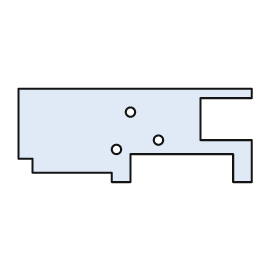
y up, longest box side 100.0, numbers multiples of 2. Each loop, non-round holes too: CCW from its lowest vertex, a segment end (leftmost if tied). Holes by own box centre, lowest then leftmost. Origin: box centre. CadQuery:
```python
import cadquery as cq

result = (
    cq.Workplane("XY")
    .moveTo(-10.0, -20.0)
    .lineTo(-2.0, -20.0)
    .lineTo(-2.0, -8.0)
    .lineTo(42.0, -8.0)
    .lineTo(42.0, -20.0)
    .lineTo(50.0, -20.0)
    .lineTo(50.0, -2.0)
    .lineTo(28.0, -2.0)
    .lineTo(28.0, 16.0)
    .lineTo(50.0, 16.0)
    .lineTo(50.0, 20.0)
    .lineTo(-50.0, 20.0)
    .lineTo(-50.0, -10.0)
    .lineTo(-44.0, -10.0)
    .lineTo(-44.0, -16.0)
    .lineTo(-10.0, -16.0)
    .close()
    .moveTo(-8.0, -6.0)
    .circle(2.0)
    .moveTo(10.0, -2.0)
    .circle(2.0)
    .moveTo(-2.0, 10.0)
    .circle(2.0)
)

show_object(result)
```